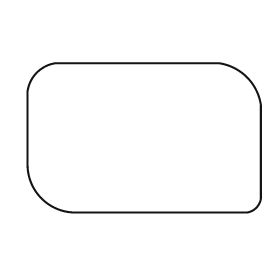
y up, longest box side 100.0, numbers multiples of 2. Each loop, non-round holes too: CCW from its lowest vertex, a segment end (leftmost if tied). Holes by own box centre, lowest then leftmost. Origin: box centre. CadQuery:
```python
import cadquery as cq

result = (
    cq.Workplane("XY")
    .moveTo(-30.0, -32.0)
    .lineTo(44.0, -32.0)
    .threePointArc((48.0, -30.0), (50.0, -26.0))
    .lineTo(50.0, 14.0)
    .threePointArc((44.0, 26.0), (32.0, 32.0))
    .lineTo(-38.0, 32.0)
    .threePointArc((-46.0, 28.0), (-50.0, 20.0))
    .lineTo(-50.0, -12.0)
    .threePointArc((-44.0, -26.0), (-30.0, -32.0))
    .close()
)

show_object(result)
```